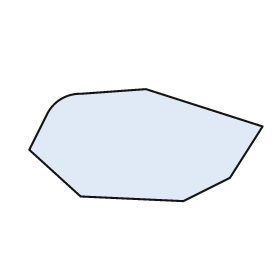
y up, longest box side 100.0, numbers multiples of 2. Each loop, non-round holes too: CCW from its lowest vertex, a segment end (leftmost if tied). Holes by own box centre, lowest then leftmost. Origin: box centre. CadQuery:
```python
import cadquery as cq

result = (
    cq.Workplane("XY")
    .moveTo(16.0, -24.0)
    .lineTo(36.0, -14.0)
    .lineTo(50.0, 8.0)
    .lineTo(0.0, 24.0)
    .lineTo(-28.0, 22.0)
    .threePointArc((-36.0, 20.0), (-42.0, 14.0))
    .lineTo(-50.0, -2.0)
    .lineTo(-28.0, -22.0)
    .close()
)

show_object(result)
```